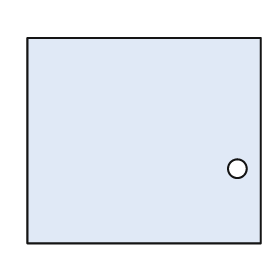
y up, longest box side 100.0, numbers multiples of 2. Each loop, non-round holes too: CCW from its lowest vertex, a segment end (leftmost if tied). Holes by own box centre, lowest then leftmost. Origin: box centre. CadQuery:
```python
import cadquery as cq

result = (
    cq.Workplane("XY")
    .moveTo(-50.0, -44.0)
    .lineTo(50.0, -44.0)
    .lineTo(50.0, 44.0)
    .lineTo(-50.0, 44.0)
    .close()
    .moveTo(40.0, -12.0)
    .circle(4.0)
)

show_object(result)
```